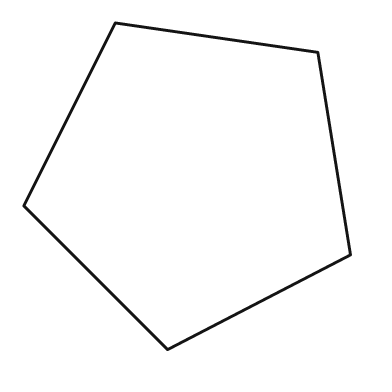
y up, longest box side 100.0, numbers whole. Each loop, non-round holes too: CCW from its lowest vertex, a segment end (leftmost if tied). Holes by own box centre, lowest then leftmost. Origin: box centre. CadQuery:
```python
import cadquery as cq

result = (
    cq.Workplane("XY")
    .moveTo(-6.0, -50.0)
    .lineTo(50.0, -21.0)
    .lineTo(40.0, 41.0)
    .lineTo(-22.0, 50.0)
    .lineTo(-50.0, -6.0)
    .close()
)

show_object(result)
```